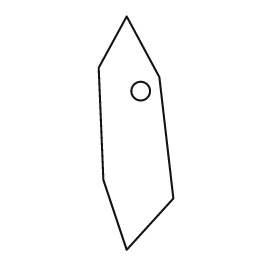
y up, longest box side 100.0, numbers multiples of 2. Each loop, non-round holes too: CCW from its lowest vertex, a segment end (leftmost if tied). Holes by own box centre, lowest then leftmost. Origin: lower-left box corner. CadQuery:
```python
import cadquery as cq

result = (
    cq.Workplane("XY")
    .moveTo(12.0, 0.0)
    .lineTo(32.0, 22.0)
    .lineTo(26.0, 74.0)
    .lineTo(12.0, 100.0)
    .lineTo(0.0, 78.0)
    .lineTo(2.0, 30.0)
    .close()
    .moveTo(18.0, 68.0)
    .circle(4.0)
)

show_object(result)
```